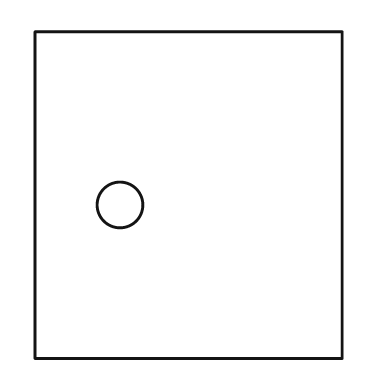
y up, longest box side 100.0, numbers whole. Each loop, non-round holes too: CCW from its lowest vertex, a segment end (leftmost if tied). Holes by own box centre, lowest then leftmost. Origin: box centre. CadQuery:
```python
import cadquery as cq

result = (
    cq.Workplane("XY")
    .moveTo(-47.0, -50.0)
    .lineTo(47.0, -50.0)
    .lineTo(47.0, 50.0)
    .lineTo(-47.0, 50.0)
    .close()
    .moveTo(-21.0, -3.0)
    .circle(7.0)
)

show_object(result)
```